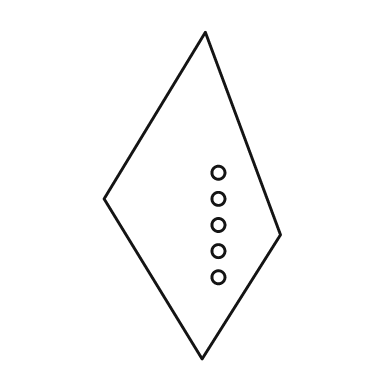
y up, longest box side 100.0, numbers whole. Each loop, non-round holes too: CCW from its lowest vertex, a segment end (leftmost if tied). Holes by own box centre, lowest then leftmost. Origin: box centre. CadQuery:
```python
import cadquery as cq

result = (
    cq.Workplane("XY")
    .moveTo(3.0, -50.0)
    .lineTo(27.0, -12.0)
    .lineTo(4.0, 50.0)
    .lineTo(-27.0, -1.0)
    .close()
    .moveTo(8.0, -25.0)
    .circle(2.0)
    .moveTo(8.0, -17.0)
    .circle(2.0)
    .moveTo(8.0, -9.0)
    .circle(2.0)
    .moveTo(8.0, -1.0)
    .circle(2.0)
    .moveTo(8.0, 7.0)
    .circle(2.0)
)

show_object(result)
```